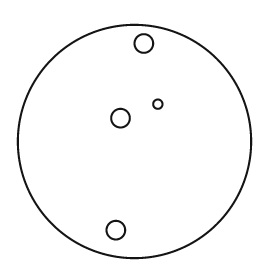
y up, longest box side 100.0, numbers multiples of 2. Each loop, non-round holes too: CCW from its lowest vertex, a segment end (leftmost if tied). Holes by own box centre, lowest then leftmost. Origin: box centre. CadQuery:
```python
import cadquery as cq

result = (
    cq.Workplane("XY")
    .moveTo(0.0, 0.0)
    .circle(50.0)
    .moveTo(-8.0, -38.0)
    .circle(4.0)
    .moveTo(-6.0, 10.0)
    .circle(4.0)
    .moveTo(10.0, 16.0)
    .circle(2.0)
    .moveTo(4.0, 42.0)
    .circle(4.0)
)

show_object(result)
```